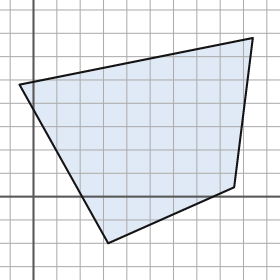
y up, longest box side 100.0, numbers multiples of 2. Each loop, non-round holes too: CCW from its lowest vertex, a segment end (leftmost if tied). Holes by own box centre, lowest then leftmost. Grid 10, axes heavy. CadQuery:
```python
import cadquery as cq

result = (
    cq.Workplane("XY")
    .moveTo(32.0, -20.0)
    .lineTo(86.0, 4.0)
    .lineTo(94.0, 68.0)
    .lineTo(-6.0, 48.0)
    .close()
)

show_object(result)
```